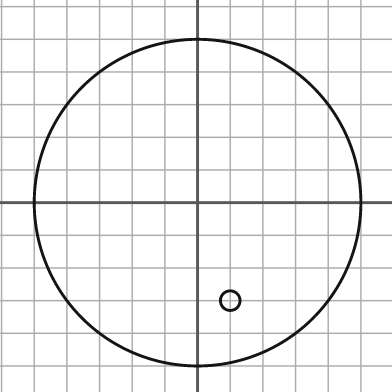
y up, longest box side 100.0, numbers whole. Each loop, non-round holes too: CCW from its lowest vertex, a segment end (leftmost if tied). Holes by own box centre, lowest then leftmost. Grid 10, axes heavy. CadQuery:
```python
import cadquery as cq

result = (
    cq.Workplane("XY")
    .moveTo(0.0, 0.0)
    .circle(50.0)
    .moveTo(10.0, -30.0)
    .circle(3.0)
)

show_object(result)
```